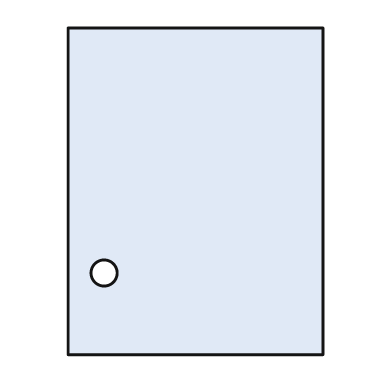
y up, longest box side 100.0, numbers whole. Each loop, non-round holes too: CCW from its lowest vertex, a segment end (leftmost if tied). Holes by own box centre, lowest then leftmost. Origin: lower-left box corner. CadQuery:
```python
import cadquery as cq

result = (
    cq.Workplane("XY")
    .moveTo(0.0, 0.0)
    .lineTo(78.0, 0.0)
    .lineTo(78.0, 100.0)
    .lineTo(0.0, 100.0)
    .close()
    .moveTo(11.0, 25.0)
    .circle(4.0)
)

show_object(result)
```